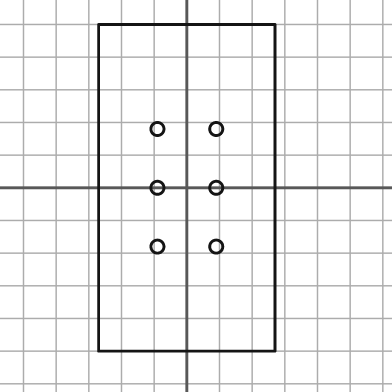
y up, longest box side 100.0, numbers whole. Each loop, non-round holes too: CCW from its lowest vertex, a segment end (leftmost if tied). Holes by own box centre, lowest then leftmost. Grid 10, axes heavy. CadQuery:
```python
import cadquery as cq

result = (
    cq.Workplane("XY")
    .moveTo(-27.0, -50.0)
    .lineTo(27.0, -50.0)
    .lineTo(27.0, 50.0)
    .lineTo(-27.0, 50.0)
    .close()
    .moveTo(-9.0, -18.0)
    .circle(2.0)
    .moveTo(9.0, -18.0)
    .circle(2.0)
    .moveTo(-9.0, 0.0)
    .circle(2.0)
    .moveTo(9.0, 0.0)
    .circle(2.0)
    .moveTo(-9.0, 18.0)
    .circle(2.0)
    .moveTo(9.0, 18.0)
    .circle(2.0)
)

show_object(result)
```